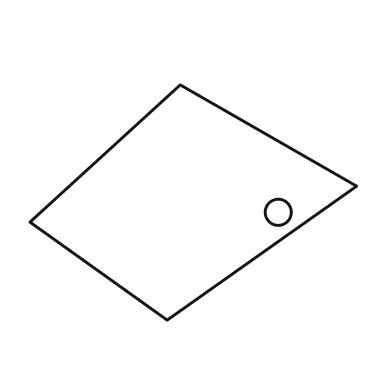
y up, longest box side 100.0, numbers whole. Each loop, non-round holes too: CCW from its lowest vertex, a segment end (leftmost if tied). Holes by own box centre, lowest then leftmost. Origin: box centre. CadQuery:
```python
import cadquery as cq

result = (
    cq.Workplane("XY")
    .moveTo(-8.0, -36.0)
    .lineTo(50.0, 5.0)
    .lineTo(-4.0, 36.0)
    .lineTo(-50.0, -6.0)
    .close()
    .moveTo(26.0, -3.0)
    .circle(4.0)
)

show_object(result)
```